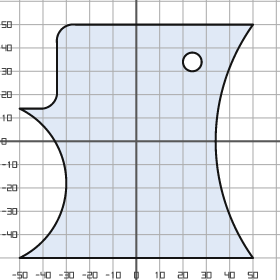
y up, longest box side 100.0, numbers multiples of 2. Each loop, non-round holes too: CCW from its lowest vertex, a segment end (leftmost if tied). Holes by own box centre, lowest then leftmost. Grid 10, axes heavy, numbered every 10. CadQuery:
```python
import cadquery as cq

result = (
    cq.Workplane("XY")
    .moveTo(-50.0, -50.0)
    .lineTo(50.0, -50.0)
    .threePointArc((34.0, 0.0), (50.0, 50.0))
    .lineTo(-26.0, 50.0)
    .threePointArc((-32.0, 48.0), (-34.0, 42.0))
    .lineTo(-34.0, 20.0)
    .threePointArc((-36.0, 16.0), (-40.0, 14.0))
    .lineTo(-50.0, 14.0)
    .threePointArc((-30.0, -18.0), (-50.0, -50.0))
    .close()
    .moveTo(24.0, 34.0)
    .circle(4.0)
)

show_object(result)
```